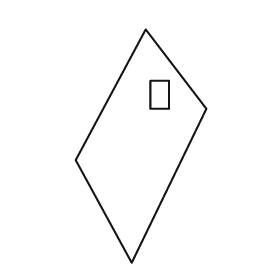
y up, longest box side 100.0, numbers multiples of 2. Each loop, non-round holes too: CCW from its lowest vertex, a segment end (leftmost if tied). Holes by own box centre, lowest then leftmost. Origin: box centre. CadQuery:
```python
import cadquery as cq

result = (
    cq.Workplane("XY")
    .moveTo(-4.0, -50.0)
    .lineTo(28.0, 16.0)
    .lineTo(2.0, 50.0)
    .lineTo(-28.0, -6.0)
    .close()
    .moveTo(4.0, 16.0)
    .lineTo(12.0, 16.0)
    .lineTo(12.0, 28.0)
    .lineTo(4.0, 28.0)
    .close()
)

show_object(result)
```